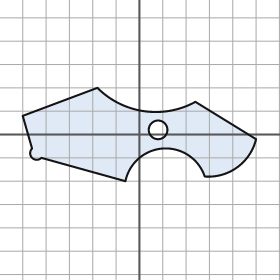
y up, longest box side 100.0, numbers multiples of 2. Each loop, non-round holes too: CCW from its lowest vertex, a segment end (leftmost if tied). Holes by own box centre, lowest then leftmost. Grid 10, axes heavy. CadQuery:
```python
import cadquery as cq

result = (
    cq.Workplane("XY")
    .moveTo(-6.0, -20.0)
    .threePointArc((10.0, -6.0), (28.0, -18.0))
    .threePointArc((42.0, -14.0), (50.0, -2.0))
    .lineTo(24.0, 14.0)
    .threePointArc((2.0, 10.0), (-18.0, 20.0))
    .lineTo(-50.0, 8.0)
    .lineTo(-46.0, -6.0)
    .threePointArc((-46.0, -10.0), (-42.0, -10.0))
    .close()
    .moveTo(8.0, 2.0)
    .circle(4.0)
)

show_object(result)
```